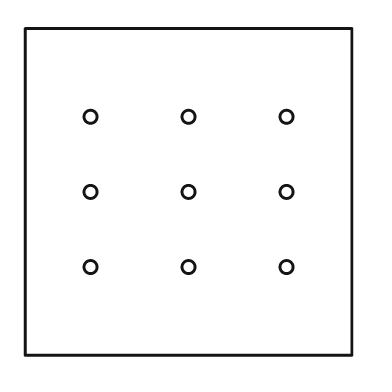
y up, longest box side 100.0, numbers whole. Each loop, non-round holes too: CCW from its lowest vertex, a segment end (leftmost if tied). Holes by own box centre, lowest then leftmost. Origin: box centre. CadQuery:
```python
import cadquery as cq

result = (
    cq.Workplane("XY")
    .moveTo(-50.0, -50.0)
    .lineTo(50.0, -50.0)
    .lineTo(50.0, 50.0)
    .lineTo(-50.0, 50.0)
    .close()
    .moveTo(-30.0, -23.0)
    .circle(2.0)
    .moveTo(0.0, -23.0)
    .circle(2.0)
    .moveTo(30.0, -23.0)
    .circle(2.0)
    .moveTo(-30.0, 0.0)
    .circle(2.0)
    .moveTo(0.0, 0.0)
    .circle(2.0)
    .moveTo(30.0, 0.0)
    .circle(2.0)
    .moveTo(-30.0, 23.0)
    .circle(2.0)
    .moveTo(0.0, 23.0)
    .circle(2.0)
    .moveTo(30.0, 23.0)
    .circle(2.0)
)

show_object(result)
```